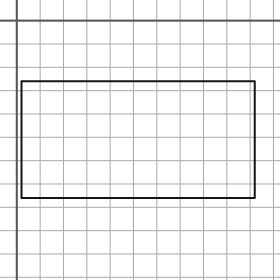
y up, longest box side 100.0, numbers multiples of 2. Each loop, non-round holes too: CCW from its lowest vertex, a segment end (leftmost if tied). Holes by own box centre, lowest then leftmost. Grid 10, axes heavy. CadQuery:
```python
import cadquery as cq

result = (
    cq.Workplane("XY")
    .moveTo(2.0, -76.0)
    .lineTo(102.0, -76.0)
    .lineTo(102.0, -26.0)
    .lineTo(2.0, -26.0)
    .close()
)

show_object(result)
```